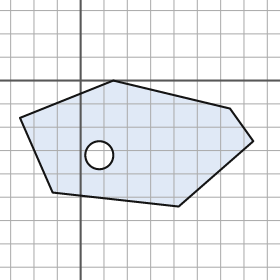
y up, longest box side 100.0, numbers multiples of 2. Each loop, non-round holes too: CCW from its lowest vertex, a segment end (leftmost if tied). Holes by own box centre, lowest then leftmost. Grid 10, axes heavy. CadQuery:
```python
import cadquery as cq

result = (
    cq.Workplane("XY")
    .moveTo(42.0, -54.0)
    .lineTo(74.0, -26.0)
    .lineTo(64.0, -12.0)
    .lineTo(14.0, 0.0)
    .lineTo(-26.0, -16.0)
    .lineTo(-12.0, -48.0)
    .close()
    .moveTo(8.0, -32.0)
    .circle(6.0)
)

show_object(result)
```